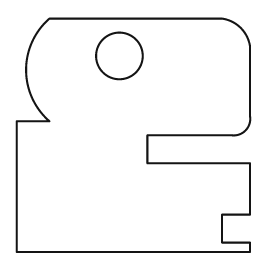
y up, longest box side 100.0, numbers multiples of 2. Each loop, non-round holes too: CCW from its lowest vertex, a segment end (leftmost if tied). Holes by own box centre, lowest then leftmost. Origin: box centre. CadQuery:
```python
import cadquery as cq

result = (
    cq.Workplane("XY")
    .moveTo(-50.0, -50.0)
    .lineTo(50.0, -50.0)
    .lineTo(50.0, -46.0)
    .lineTo(38.0, -46.0)
    .lineTo(38.0, -34.0)
    .lineTo(50.0, -34.0)
    .lineTo(50.0, -12.0)
    .lineTo(6.0, -12.0)
    .lineTo(6.0, 0.0)
    .lineTo(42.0, 0.0)
    .threePointArc((48.0, 2.0), (50.0, 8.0))
    .lineTo(50.0, 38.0)
    .threePointArc((46.0, 46.0), (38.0, 50.0))
    .lineTo(-36.0, 50.0)
    .threePointArc((-46.0, 28.0), (-36.0, 6.0))
    .lineTo(-50.0, 6.0)
    .close()
    .moveTo(-6.0, 34.0)
    .circle(10.0)
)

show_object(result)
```